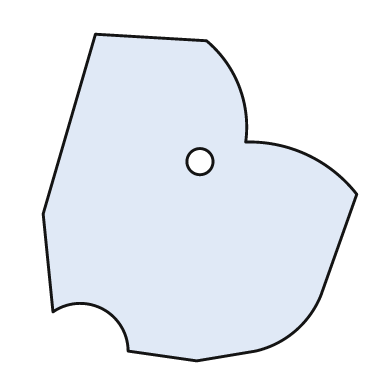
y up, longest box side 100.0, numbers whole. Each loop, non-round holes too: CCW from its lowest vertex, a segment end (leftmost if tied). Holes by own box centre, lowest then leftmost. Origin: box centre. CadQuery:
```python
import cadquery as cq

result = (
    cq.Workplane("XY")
    .moveTo(-1.0, -50.0)
    .lineTo(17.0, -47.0)
    .threePointArc((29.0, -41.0), (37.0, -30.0))
    .lineTo(48.0, 1.0)
    .threePointArc((33.0, 13.0), (14.0, 17.0))
    .threePointArc((12.0, 34.0), (2.0, 48.0))
    .lineTo(-32.0, 50.0)
    .lineTo(-48.0, -5.0)
    .lineTo(-45.0, -35.0)
    .threePointArc((-30.0, -34.0), (-22.0, -47.0))
    .close()
    .moveTo(0.0, 11.0)
    .circle(4.0)
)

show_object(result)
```